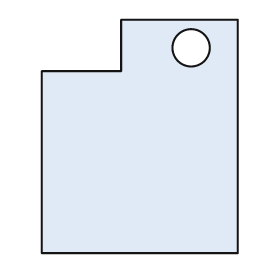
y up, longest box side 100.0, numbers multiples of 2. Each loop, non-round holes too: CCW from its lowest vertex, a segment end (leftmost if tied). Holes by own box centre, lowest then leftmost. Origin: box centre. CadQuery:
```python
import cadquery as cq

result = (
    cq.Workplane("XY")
    .moveTo(-42.0, -50.0)
    .lineTo(42.0, -50.0)
    .lineTo(42.0, 50.0)
    .lineTo(-8.0, 50.0)
    .lineTo(-8.0, 28.0)
    .lineTo(-42.0, 28.0)
    .close()
    .moveTo(22.0, 38.0)
    .circle(8.0)
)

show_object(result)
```